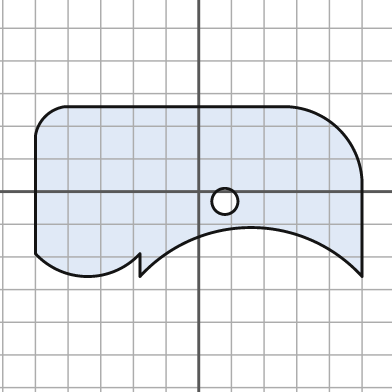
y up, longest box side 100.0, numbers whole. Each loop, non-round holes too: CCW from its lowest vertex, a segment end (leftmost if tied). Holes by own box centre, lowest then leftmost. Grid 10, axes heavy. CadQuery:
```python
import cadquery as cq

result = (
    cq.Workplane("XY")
    .moveTo(-18.0, -26.0)
    .threePointArc((16.0, -11.0), (50.0, -26.0))
    .lineTo(50.0, 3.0)
    .threePointArc((43.0, 19.0), (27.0, 26.0))
    .lineTo(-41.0, 26.0)
    .threePointArc((-47.0, 23.0), (-50.0, 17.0))
    .lineTo(-50.0, -19.0)
    .threePointArc((-34.0, -26.0), (-18.0, -19.0))
    .close()
    .moveTo(8.0, -3.0)
    .circle(4.0)
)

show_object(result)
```